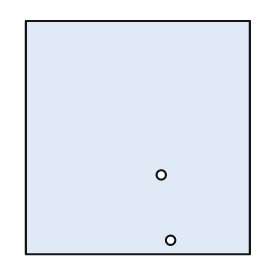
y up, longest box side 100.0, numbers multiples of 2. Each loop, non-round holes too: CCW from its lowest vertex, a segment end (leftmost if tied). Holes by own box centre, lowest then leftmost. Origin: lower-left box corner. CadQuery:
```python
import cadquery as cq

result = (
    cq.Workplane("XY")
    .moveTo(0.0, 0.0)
    .lineTo(96.0, 0.0)
    .lineTo(96.0, 100.0)
    .lineTo(0.0, 100.0)
    .close()
    .moveTo(62.0, 6.0)
    .circle(2.0)
    .moveTo(58.0, 34.0)
    .circle(2.0)
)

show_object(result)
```